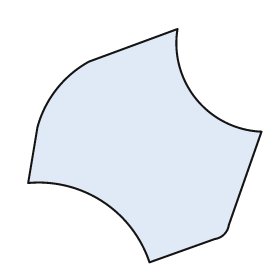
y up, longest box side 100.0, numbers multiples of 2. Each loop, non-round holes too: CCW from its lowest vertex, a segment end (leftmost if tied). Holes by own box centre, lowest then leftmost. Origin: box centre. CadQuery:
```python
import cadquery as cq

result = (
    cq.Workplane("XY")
    .moveTo(2.0, -50.0)
    .lineTo(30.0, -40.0)
    .threePointArc((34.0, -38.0), (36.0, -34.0))
    .lineTo(50.0, 6.0)
    .threePointArc((22.0, 20.0), (14.0, 50.0))
    .lineTo(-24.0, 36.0)
    .threePointArc((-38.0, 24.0), (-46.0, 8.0))
    .lineTo(-50.0, -16.0)
    .threePointArc((-18.0, -24.0), (2.0, -50.0))
    .close()
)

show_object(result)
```